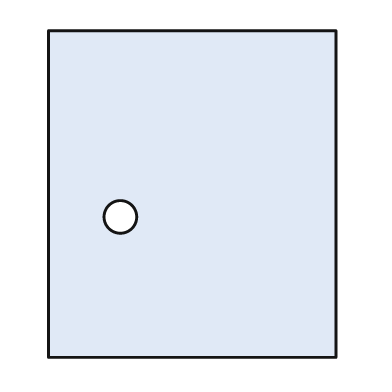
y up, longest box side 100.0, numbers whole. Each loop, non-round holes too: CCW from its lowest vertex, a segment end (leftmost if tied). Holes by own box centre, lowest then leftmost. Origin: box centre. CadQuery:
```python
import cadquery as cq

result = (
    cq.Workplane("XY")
    .moveTo(-44.0, -50.0)
    .lineTo(44.0, -50.0)
    .lineTo(44.0, 50.0)
    .lineTo(-44.0, 50.0)
    .close()
    .moveTo(-22.0, -7.0)
    .circle(5.0)
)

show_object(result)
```